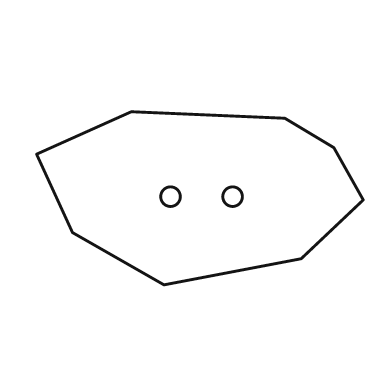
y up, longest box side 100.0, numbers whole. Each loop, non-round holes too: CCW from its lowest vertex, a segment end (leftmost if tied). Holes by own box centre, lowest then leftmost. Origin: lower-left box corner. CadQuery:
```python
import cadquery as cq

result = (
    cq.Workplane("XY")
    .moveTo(39.0, 0.0)
    .lineTo(81.0, 8.0)
    .lineTo(100.0, 26.0)
    .lineTo(91.0, 42.0)
    .lineTo(76.0, 51.0)
    .lineTo(29.0, 53.0)
    .lineTo(0.0, 40.0)
    .lineTo(11.0, 16.0)
    .close()
    .moveTo(41.0, 27.0)
    .circle(3.0)
    .moveTo(60.0, 27.0)
    .circle(3.0)
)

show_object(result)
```